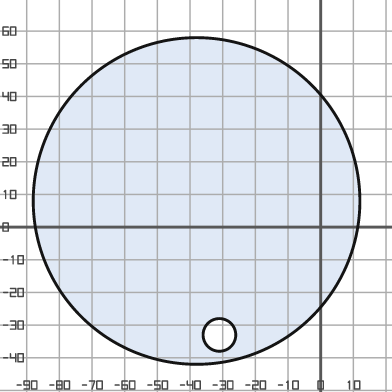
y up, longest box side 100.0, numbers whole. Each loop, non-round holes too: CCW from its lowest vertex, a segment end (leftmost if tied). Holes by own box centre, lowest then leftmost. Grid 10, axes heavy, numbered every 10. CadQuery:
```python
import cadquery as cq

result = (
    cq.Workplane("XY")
    .moveTo(-38.0, 8.0)
    .circle(50.0)
    .moveTo(-31.0, -33.0)
    .circle(5.0)
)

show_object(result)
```